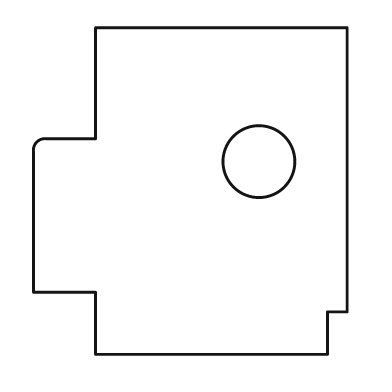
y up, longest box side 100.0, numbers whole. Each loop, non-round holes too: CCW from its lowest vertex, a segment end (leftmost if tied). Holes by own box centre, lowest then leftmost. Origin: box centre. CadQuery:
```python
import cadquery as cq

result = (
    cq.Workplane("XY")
    .moveTo(-29.0, -50.0)
    .lineTo(42.0, -50.0)
    .lineTo(42.0, -37.0)
    .lineTo(48.0, -37.0)
    .lineTo(48.0, 50.0)
    .lineTo(-29.0, 50.0)
    .lineTo(-29.0, 16.0)
    .lineTo(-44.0, 16.0)
    .threePointArc((-47.0, 15.0), (-48.0, 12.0))
    .lineTo(-48.0, -31.0)
    .lineTo(-29.0, -31.0)
    .close()
    .moveTo(21.0, 9.0)
    .circle(11.0)
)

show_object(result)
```